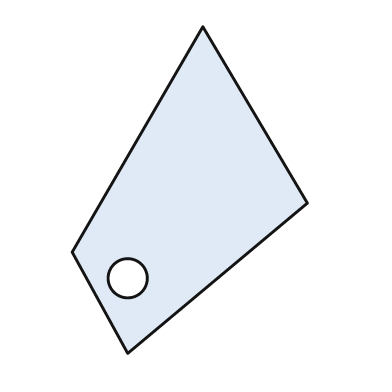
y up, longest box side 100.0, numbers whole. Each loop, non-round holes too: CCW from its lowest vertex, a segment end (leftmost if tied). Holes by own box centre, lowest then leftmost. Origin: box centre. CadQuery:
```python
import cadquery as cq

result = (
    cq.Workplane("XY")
    .moveTo(-19.0, -50.0)
    .lineTo(36.0, -4.0)
    .lineTo(4.0, 50.0)
    .lineTo(-36.0, -19.0)
    .close()
    .moveTo(-19.0, -27.0)
    .circle(6.0)
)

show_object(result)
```